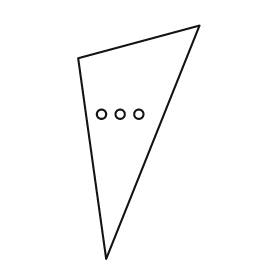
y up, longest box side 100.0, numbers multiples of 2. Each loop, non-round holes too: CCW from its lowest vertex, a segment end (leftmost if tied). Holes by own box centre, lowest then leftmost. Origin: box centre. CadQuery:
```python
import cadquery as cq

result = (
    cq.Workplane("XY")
    .moveTo(-14.0, -50.0)
    .lineTo(26.0, 50.0)
    .lineTo(-26.0, 36.0)
    .close()
    .moveTo(-16.0, 12.0)
    .circle(2.0)
    .moveTo(-8.0, 12.0)
    .circle(2.0)
    .moveTo(0.0, 12.0)
    .circle(2.0)
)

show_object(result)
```